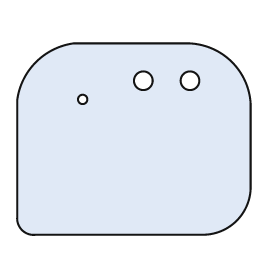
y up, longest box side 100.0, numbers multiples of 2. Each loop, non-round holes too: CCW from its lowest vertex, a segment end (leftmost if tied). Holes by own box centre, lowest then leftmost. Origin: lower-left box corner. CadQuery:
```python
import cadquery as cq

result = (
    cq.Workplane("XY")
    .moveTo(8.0, 0.0)
    .lineTo(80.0, 0.0)
    .threePointArc((94.0, 6.0), (100.0, 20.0))
    .lineTo(100.0, 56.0)
    .threePointArc((92.0, 74.0), (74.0, 82.0))
    .lineTo(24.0, 82.0)
    .threePointArc((8.0, 74.0), (0.0, 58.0))
    .lineTo(0.0, 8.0)
    .threePointArc((2.0, 2.0), (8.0, 0.0))
    .close()
    .moveTo(28.0, 58.0)
    .circle(2.0)
    .moveTo(54.0, 66.0)
    .circle(4.0)
    .moveTo(74.0, 66.0)
    .circle(4.0)
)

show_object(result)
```